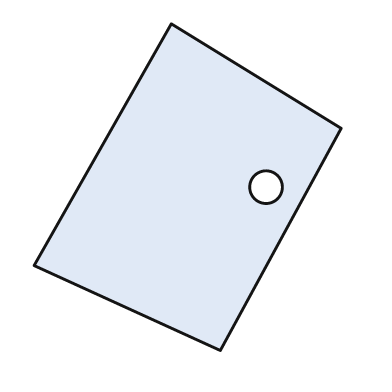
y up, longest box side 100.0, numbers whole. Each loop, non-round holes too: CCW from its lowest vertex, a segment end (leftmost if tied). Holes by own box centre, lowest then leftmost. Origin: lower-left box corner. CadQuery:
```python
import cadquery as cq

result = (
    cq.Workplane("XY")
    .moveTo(57.0, 0.0)
    .lineTo(94.0, 68.0)
    .lineTo(42.0, 100.0)
    .lineTo(0.0, 26.0)
    .close()
    .moveTo(71.0, 50.0)
    .circle(5.0)
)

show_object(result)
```